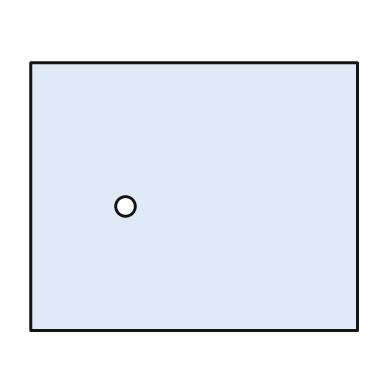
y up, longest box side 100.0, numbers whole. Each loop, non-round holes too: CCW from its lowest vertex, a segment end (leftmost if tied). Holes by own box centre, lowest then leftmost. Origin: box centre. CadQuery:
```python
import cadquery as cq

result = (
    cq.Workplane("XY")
    .moveTo(-50.0, -41.0)
    .lineTo(50.0, -41.0)
    .lineTo(50.0, 41.0)
    .lineTo(-50.0, 41.0)
    .close()
    .moveTo(-21.0, -3.0)
    .circle(3.0)
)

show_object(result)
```